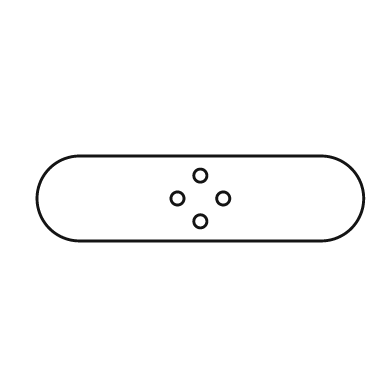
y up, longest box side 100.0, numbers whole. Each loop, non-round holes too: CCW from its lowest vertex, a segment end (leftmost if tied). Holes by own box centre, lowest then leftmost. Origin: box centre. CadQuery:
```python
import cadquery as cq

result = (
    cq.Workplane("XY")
    .moveTo(-37.0, -13.0)
    .lineTo(37.0, -13.0)
    .threePointArc((50.0, 0.0), (37.0, 13.0))
    .lineTo(-37.0, 13.0)
    .threePointArc((-50.0, 0.0), (-37.0, -13.0))
    .close()
    .moveTo(0.0, -7.0)
    .circle(2.0)
    .moveTo(-7.0, 0.0)
    .circle(2.0)
    .moveTo(7.0, 0.0)
    .circle(2.0)
    .moveTo(0.0, 7.0)
    .circle(2.0)
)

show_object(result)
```